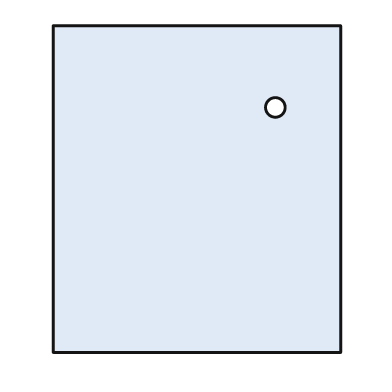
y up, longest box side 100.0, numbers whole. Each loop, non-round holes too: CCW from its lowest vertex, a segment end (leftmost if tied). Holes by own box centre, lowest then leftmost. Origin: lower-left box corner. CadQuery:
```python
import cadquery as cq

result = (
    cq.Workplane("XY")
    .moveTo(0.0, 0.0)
    .lineTo(88.0, 0.0)
    .lineTo(88.0, 100.0)
    .lineTo(0.0, 100.0)
    .close()
    .moveTo(68.0, 75.0)
    .circle(3.0)
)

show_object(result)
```